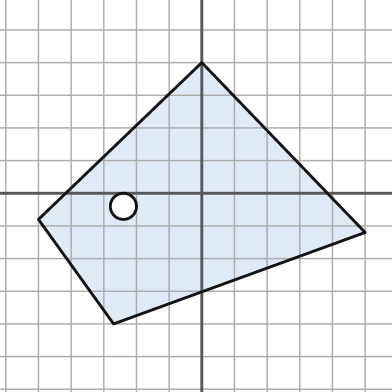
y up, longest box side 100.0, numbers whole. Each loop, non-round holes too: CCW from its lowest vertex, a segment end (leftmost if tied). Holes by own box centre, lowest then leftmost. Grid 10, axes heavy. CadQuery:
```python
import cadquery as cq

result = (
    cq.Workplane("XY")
    .moveTo(-27.0, -40.0)
    .lineTo(50.0, -12.0)
    .lineTo(0.0, 40.0)
    .lineTo(-50.0, -8.0)
    .close()
    .moveTo(-24.0, -4.0)
    .circle(4.0)
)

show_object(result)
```